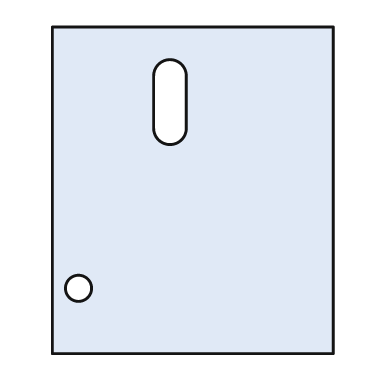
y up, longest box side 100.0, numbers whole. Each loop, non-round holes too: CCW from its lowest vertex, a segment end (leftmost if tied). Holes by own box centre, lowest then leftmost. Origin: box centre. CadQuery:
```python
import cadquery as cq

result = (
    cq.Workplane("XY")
    .moveTo(-43.0, -50.0)
    .lineTo(43.0, -50.0)
    .lineTo(43.0, 50.0)
    .lineTo(-43.0, 50.0)
    .close()
    .moveTo(-35.0, -30.0)
    .circle(4.0)
    .moveTo(-12.0, 19.0)
    .threePointArc((-7.0, 14.0), (-2.0, 19.0))
    .lineTo(-2.0, 35.0)
    .threePointArc((-7.0, 40.0), (-12.0, 35.0))
    .close()
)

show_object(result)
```